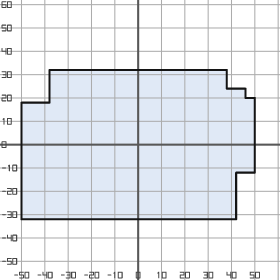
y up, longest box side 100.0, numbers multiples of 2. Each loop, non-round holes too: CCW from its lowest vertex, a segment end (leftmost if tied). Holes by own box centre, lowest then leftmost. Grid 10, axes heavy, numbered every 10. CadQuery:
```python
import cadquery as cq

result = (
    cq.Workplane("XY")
    .moveTo(-50.0, -32.0)
    .lineTo(42.0, -32.0)
    .lineTo(42.0, -12.0)
    .lineTo(50.0, -12.0)
    .lineTo(50.0, 20.0)
    .lineTo(46.0, 20.0)
    .lineTo(46.0, 24.0)
    .lineTo(38.0, 24.0)
    .lineTo(38.0, 32.0)
    .lineTo(-38.0, 32.0)
    .lineTo(-38.0, 18.0)
    .lineTo(-50.0, 18.0)
    .close()
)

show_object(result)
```